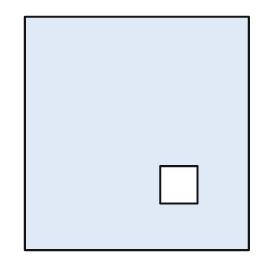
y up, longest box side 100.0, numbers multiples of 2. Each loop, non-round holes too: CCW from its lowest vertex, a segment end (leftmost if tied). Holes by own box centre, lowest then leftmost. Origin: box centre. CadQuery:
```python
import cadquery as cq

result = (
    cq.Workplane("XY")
    .moveTo(-48.0, -50.0)
    .lineTo(48.0, -50.0)
    .lineTo(48.0, 50.0)
    .lineTo(-48.0, 50.0)
    .close()
    .moveTo(10.0, -30.0)
    .lineTo(26.0, -30.0)
    .lineTo(26.0, -14.0)
    .lineTo(10.0, -14.0)
    .close()
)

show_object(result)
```